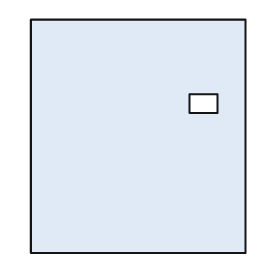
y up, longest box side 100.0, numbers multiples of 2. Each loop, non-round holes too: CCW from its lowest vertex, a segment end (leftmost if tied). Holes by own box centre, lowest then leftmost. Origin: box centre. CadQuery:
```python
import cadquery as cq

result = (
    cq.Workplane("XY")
    .moveTo(-46.0, -50.0)
    .lineTo(46.0, -50.0)
    .lineTo(46.0, 50.0)
    .lineTo(-46.0, 50.0)
    .close()
    .moveTo(22.0, 10.0)
    .lineTo(34.0, 10.0)
    .lineTo(34.0, 18.0)
    .lineTo(22.0, 18.0)
    .close()
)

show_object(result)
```